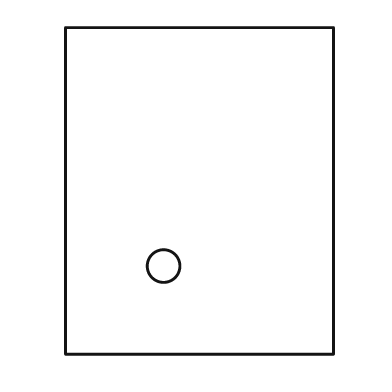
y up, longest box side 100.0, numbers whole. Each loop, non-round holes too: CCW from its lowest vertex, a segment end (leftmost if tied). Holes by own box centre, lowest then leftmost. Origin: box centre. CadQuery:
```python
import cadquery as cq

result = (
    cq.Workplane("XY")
    .moveTo(-41.0, -50.0)
    .lineTo(41.0, -50.0)
    .lineTo(41.0, 50.0)
    .lineTo(-41.0, 50.0)
    .close()
    .moveTo(-11.0, -23.0)
    .circle(5.0)
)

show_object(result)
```